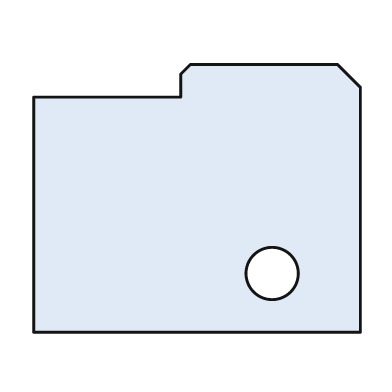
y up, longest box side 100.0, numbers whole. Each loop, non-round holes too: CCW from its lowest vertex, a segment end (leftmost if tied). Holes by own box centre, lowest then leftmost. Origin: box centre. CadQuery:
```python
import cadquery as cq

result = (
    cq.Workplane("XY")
    .moveTo(-50.0, -41.0)
    .lineTo(50.0, -41.0)
    .lineTo(50.0, 34.0)
    .lineTo(43.0, 41.0)
    .lineTo(-2.0, 41.0)
    .lineTo(-5.0, 38.0)
    .lineTo(-5.0, 31.0)
    .lineTo(-50.0, 31.0)
    .close()
    .moveTo(23.0, -23.0)
    .circle(8.0)
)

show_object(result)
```